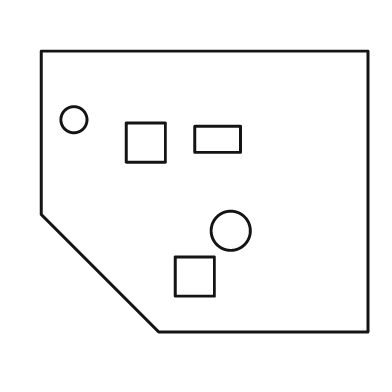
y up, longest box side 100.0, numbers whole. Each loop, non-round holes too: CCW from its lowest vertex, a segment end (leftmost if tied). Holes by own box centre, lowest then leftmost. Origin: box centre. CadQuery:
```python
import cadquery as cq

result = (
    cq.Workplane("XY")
    .moveTo(-14.0, -43.0)
    .lineTo(50.0, -43.0)
    .lineTo(50.0, 43.0)
    .lineTo(-50.0, 43.0)
    .lineTo(-50.0, -7.0)
    .close()
    .moveTo(-9.0, -32.0)
    .lineTo(3.0, -32.0)
    .lineTo(3.0, -20.0)
    .lineTo(-9.0, -20.0)
    .close()
    .moveTo(8.0, -12.0)
    .circle(6.0)
    .moveTo(-24.0, 9.0)
    .lineTo(-12.0, 9.0)
    .lineTo(-12.0, 21.0)
    .lineTo(-24.0, 21.0)
    .close()
    .moveTo(-3.0, 12.0)
    .lineTo(11.0, 12.0)
    .lineTo(11.0, 20.0)
    .lineTo(-3.0, 20.0)
    .close()
    .moveTo(-40.0, 22.0)
    .circle(4.0)
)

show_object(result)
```